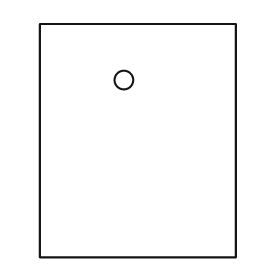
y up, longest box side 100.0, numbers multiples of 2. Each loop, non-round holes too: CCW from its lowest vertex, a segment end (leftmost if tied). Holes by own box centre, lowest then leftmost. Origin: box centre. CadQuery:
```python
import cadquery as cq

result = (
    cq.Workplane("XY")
    .moveTo(-42.0, -50.0)
    .lineTo(42.0, -50.0)
    .lineTo(42.0, 50.0)
    .lineTo(-42.0, 50.0)
    .close()
    .moveTo(-6.0, 26.0)
    .circle(4.0)
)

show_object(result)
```